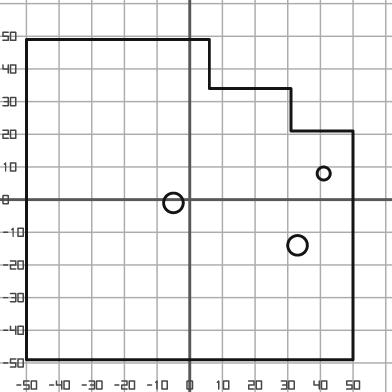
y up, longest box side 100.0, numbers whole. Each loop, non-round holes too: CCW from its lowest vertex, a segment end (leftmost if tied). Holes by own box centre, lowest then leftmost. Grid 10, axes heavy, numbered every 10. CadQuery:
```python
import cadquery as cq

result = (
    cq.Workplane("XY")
    .moveTo(-50.0, -49.0)
    .lineTo(50.0, -49.0)
    .lineTo(50.0, 21.0)
    .lineTo(31.0, 21.0)
    .lineTo(31.0, 34.0)
    .lineTo(6.0, 34.0)
    .lineTo(6.0, 49.0)
    .lineTo(-50.0, 49.0)
    .close()
    .moveTo(33.0, -14.0)
    .circle(3.0)
    .moveTo(-5.0, -1.0)
    .circle(3.0)
    .moveTo(41.0, 8.0)
    .circle(2.0)
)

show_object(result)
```